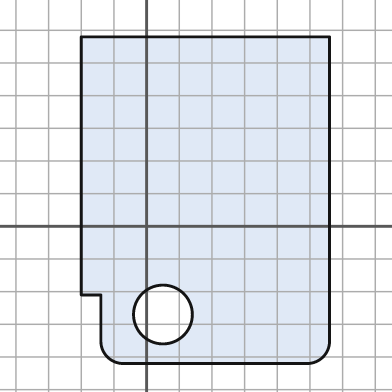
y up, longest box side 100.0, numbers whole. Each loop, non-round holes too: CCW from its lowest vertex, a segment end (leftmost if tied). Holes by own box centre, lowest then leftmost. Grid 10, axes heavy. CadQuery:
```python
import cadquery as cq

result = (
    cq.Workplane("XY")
    .moveTo(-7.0, -42.0)
    .lineTo(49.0, -42.0)
    .threePointArc((54.0, -40.0), (56.0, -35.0))
    .lineTo(56.0, 58.0)
    .lineTo(-20.0, 58.0)
    .lineTo(-20.0, -21.0)
    .lineTo(-14.0, -21.0)
    .lineTo(-14.0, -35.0)
    .threePointArc((-12.0, -40.0), (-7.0, -42.0))
    .close()
    .moveTo(5.0, -27.0)
    .circle(9.0)
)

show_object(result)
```